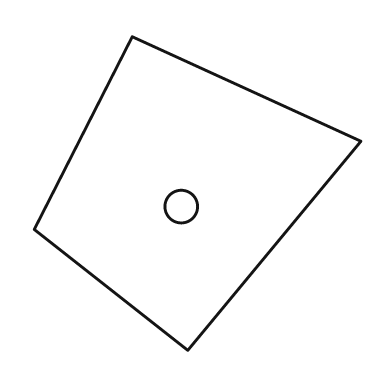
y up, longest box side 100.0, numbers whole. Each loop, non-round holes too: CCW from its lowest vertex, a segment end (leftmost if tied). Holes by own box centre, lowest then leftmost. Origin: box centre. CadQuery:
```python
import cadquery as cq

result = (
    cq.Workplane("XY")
    .moveTo(-3.0, -48.0)
    .lineTo(50.0, 16.0)
    .lineTo(-20.0, 48.0)
    .lineTo(-50.0, -11.0)
    .close()
    .moveTo(-5.0, -4.0)
    .circle(5.0)
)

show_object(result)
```